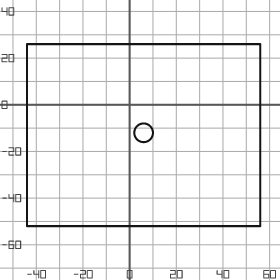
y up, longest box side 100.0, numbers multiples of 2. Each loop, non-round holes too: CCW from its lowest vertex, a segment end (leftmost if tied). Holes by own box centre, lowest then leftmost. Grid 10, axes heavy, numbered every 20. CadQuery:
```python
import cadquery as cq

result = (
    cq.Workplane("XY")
    .moveTo(-44.0, -52.0)
    .lineTo(56.0, -52.0)
    .lineTo(56.0, 26.0)
    .lineTo(-44.0, 26.0)
    .close()
    .moveTo(6.0, -12.0)
    .circle(4.0)
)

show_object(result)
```